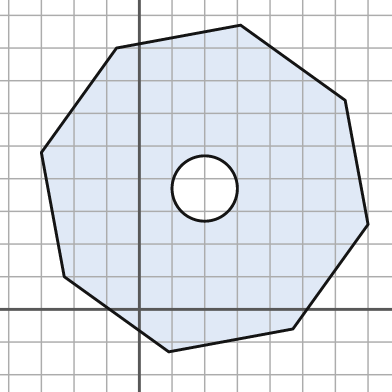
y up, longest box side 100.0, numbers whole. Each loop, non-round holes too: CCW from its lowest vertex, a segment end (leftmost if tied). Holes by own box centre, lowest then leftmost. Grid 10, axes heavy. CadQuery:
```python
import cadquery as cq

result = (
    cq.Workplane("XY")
    .moveTo(9.0, -13.0)
    .lineTo(47.0, -6.0)
    .lineTo(70.0, 26.0)
    .lineTo(63.0, 64.0)
    .lineTo(31.0, 87.0)
    .lineTo(-7.0, 80.0)
    .lineTo(-30.0, 48.0)
    .lineTo(-23.0, 10.0)
    .close()
    .moveTo(20.0, 37.0)
    .circle(10.0)
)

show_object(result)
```